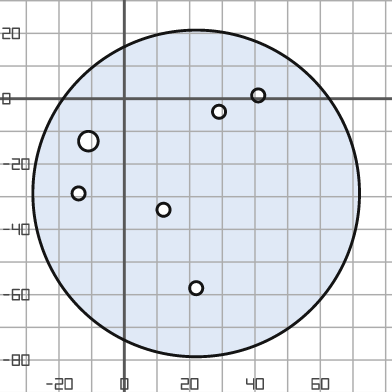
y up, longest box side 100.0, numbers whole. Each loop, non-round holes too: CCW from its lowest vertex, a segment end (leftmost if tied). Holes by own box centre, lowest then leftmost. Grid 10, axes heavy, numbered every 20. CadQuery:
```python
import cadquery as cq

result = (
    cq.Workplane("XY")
    .moveTo(22.0, -29.0)
    .circle(50.0)
    .moveTo(22.0, -58.0)
    .circle(2.0)
    .moveTo(12.0, -34.0)
    .circle(2.0)
    .moveTo(-14.0, -29.0)
    .circle(2.0)
    .moveTo(-11.0, -13.0)
    .circle(3.0)
    .moveTo(29.0, -4.0)
    .circle(2.0)
    .moveTo(41.0, 1.0)
    .circle(2.0)
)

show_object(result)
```